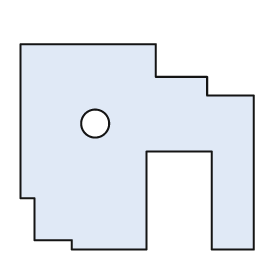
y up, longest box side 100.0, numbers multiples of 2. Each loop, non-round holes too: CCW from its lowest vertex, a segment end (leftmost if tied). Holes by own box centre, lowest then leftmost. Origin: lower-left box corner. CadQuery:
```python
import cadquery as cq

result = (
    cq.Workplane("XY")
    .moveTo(22.0, 0.0)
    .lineTo(54.0, 0.0)
    .lineTo(54.0, 42.0)
    .lineTo(82.0, 42.0)
    .lineTo(82.0, 0.0)
    .lineTo(100.0, 0.0)
    .lineTo(100.0, 66.0)
    .lineTo(80.0, 66.0)
    .lineTo(80.0, 74.0)
    .lineTo(58.0, 74.0)
    .lineTo(58.0, 88.0)
    .lineTo(0.0, 88.0)
    .lineTo(0.0, 22.0)
    .lineTo(6.0, 22.0)
    .lineTo(6.0, 4.0)
    .lineTo(22.0, 4.0)
    .close()
    .moveTo(32.0, 54.0)
    .circle(6.0)
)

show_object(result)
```